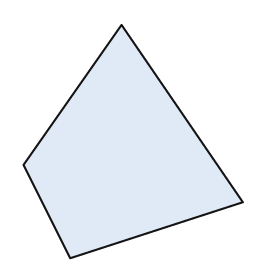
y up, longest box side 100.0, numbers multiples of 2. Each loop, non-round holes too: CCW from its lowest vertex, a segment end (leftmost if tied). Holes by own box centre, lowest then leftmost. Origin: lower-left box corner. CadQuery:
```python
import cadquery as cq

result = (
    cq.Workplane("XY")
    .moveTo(20.0, 0.0)
    .lineTo(94.0, 24.0)
    .lineTo(42.0, 100.0)
    .lineTo(0.0, 40.0)
    .close()
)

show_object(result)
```